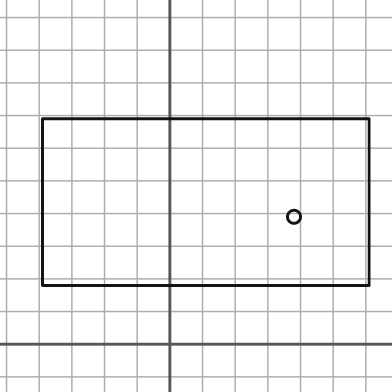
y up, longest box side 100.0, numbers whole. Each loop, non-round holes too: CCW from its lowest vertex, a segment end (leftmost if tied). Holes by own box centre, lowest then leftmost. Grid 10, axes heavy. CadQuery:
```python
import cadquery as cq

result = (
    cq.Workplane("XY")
    .moveTo(-39.0, 18.0)
    .lineTo(61.0, 18.0)
    .lineTo(61.0, 69.0)
    .lineTo(-39.0, 69.0)
    .close()
    .moveTo(38.0, 39.0)
    .circle(2.0)
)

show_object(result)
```